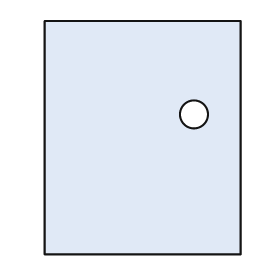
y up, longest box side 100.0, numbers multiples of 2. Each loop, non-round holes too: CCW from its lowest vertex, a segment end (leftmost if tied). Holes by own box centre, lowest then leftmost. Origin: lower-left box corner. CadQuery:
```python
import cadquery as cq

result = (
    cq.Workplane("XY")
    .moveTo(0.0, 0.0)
    .lineTo(84.0, 0.0)
    .lineTo(84.0, 100.0)
    .lineTo(0.0, 100.0)
    .close()
    .moveTo(64.0, 60.0)
    .circle(6.0)
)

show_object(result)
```